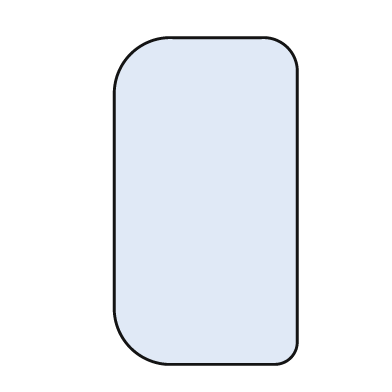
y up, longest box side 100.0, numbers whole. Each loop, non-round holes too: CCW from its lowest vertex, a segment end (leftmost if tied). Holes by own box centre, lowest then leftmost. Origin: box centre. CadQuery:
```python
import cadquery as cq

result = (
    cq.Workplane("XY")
    .moveTo(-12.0, -50.0)
    .lineTo(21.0, -50.0)
    .threePointArc((26.0, -48.0), (28.0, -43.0))
    .lineTo(28.0, 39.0)
    .threePointArc((25.0, 47.0), (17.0, 50.0))
    .lineTo(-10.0, 50.0)
    .threePointArc((-23.0, 45.0), (-28.0, 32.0))
    .lineTo(-28.0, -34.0)
    .threePointArc((-23.0, -45.0), (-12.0, -50.0))
    .close()
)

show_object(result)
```